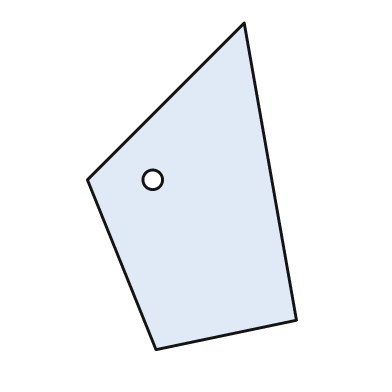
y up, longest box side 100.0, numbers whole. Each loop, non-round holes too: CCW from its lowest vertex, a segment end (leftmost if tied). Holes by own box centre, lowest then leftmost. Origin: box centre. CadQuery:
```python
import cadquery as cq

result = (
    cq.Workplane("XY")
    .moveTo(-11.0, -50.0)
    .lineTo(32.0, -41.0)
    .lineTo(16.0, 50.0)
    .lineTo(-32.0, 2.0)
    .close()
    .moveTo(-12.0, 2.0)
    .circle(3.0)
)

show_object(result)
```